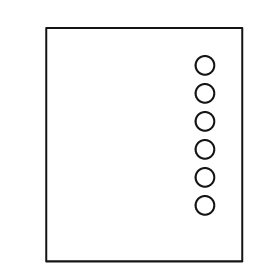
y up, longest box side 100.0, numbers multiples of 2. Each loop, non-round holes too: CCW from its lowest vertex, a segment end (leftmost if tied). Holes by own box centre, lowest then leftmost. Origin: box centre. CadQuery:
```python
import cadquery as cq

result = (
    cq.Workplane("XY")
    .moveTo(-42.0, -50.0)
    .lineTo(42.0, -50.0)
    .lineTo(42.0, 50.0)
    .lineTo(-42.0, 50.0)
    .close()
    .moveTo(26.0, -26.0)
    .circle(4.0)
    .moveTo(26.0, -14.0)
    .circle(4.0)
    .moveTo(26.0, -2.0)
    .circle(4.0)
    .moveTo(26.0, 10.0)
    .circle(4.0)
    .moveTo(26.0, 22.0)
    .circle(4.0)
    .moveTo(26.0, 34.0)
    .circle(4.0)
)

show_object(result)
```